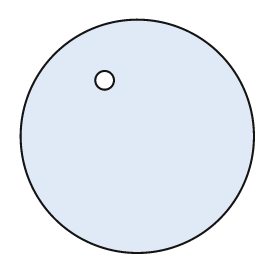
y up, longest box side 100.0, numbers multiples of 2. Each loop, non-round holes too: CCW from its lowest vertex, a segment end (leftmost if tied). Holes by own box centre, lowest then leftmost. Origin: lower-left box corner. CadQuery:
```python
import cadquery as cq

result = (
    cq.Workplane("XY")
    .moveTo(50.0, 50.0)
    .circle(50.0)
    .moveTo(36.0, 74.0)
    .circle(4.0)
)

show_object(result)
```